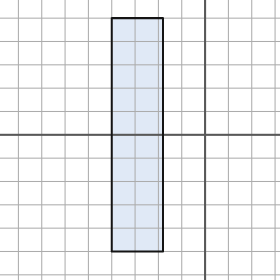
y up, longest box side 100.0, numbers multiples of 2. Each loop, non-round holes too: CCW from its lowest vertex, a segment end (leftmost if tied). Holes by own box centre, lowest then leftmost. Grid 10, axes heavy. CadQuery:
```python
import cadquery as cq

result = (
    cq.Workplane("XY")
    .moveTo(-40.0, -50.0)
    .lineTo(-18.0, -50.0)
    .lineTo(-18.0, 50.0)
    .lineTo(-40.0, 50.0)
    .close()
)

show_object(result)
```